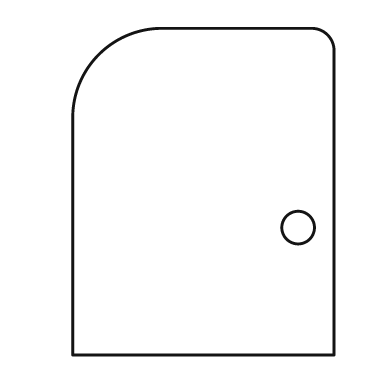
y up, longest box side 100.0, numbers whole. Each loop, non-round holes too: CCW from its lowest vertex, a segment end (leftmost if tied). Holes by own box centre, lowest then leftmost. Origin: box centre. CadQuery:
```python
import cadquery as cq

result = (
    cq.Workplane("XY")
    .moveTo(-40.0, -50.0)
    .lineTo(40.0, -50.0)
    .lineTo(40.0, 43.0)
    .threePointArc((38.0, 48.0), (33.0, 50.0))
    .lineTo(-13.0, 50.0)
    .threePointArc((-32.0, 42.0), (-40.0, 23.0))
    .close()
    .moveTo(29.0, -11.0)
    .circle(5.0)
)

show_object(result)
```